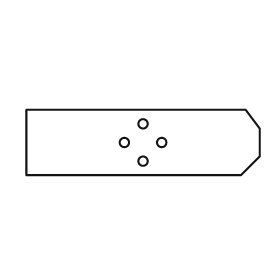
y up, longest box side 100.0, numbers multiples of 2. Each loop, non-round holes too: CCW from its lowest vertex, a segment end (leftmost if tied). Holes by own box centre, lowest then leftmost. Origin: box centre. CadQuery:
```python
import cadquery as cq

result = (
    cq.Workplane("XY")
    .moveTo(-50.0, -14.0)
    .lineTo(42.0, -14.0)
    .lineTo(50.0, -6.0)
    .lineTo(50.0, 6.0)
    .lineTo(44.0, 14.0)
    .lineTo(-50.0, 14.0)
    .close()
    .moveTo(0.0, -8.0)
    .circle(2.0)
    .moveTo(-8.0, 0.0)
    .circle(2.0)
    .moveTo(8.0, 0.0)
    .circle(2.0)
    .moveTo(0.0, 8.0)
    .circle(2.0)
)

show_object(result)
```